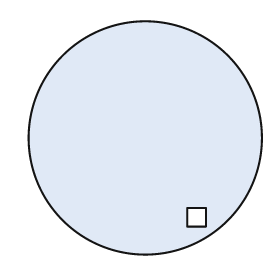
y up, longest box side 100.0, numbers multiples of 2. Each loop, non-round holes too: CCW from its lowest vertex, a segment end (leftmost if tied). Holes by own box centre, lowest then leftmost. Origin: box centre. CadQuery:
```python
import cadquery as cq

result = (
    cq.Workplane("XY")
    .moveTo(0.0, 0.0)
    .circle(50.0)
    .moveTo(18.0, -38.0)
    .lineTo(26.0, -38.0)
    .lineTo(26.0, -30.0)
    .lineTo(18.0, -30.0)
    .close()
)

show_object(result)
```